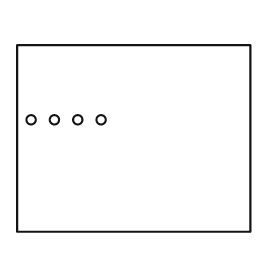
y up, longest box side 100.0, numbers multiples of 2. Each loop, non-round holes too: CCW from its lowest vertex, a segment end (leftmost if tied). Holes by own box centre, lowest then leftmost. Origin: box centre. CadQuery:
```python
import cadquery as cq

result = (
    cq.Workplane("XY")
    .moveTo(-50.0, -40.0)
    .lineTo(50.0, -40.0)
    .lineTo(50.0, 40.0)
    .lineTo(-50.0, 40.0)
    .close()
    .moveTo(-44.0, 8.0)
    .circle(2.0)
    .moveTo(-34.0, 8.0)
    .circle(2.0)
    .moveTo(-24.0, 8.0)
    .circle(2.0)
    .moveTo(-14.0, 8.0)
    .circle(2.0)
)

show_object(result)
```